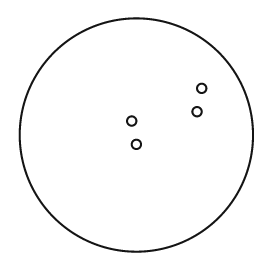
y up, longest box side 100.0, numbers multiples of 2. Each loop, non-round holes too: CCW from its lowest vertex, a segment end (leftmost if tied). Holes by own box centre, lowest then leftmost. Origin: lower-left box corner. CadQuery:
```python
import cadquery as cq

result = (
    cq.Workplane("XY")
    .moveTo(50.0, 50.0)
    .circle(50.0)
    .moveTo(50.0, 46.0)
    .circle(2.0)
    .moveTo(48.0, 56.0)
    .circle(2.0)
    .moveTo(76.0, 60.0)
    .circle(2.0)
    .moveTo(78.0, 70.0)
    .circle(2.0)
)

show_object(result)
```